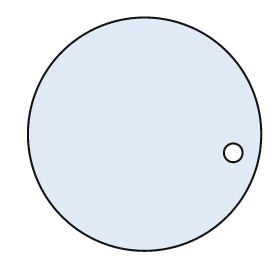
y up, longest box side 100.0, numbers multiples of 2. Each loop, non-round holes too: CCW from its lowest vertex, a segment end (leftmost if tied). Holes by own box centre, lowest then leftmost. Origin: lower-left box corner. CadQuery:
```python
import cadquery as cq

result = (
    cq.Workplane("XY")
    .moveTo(50.0, 50.0)
    .circle(50.0)
    .moveTo(88.0, 42.0)
    .circle(4.0)
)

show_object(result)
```